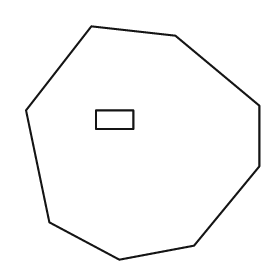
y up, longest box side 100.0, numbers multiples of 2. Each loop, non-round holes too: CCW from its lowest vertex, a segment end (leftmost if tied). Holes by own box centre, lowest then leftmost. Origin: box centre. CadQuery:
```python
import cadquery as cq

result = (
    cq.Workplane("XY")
    .moveTo(-10.0, -50.0)
    .lineTo(22.0, -44.0)
    .lineTo(50.0, -10.0)
    .lineTo(50.0, 16.0)
    .lineTo(14.0, 46.0)
    .lineTo(-22.0, 50.0)
    .lineTo(-50.0, 14.0)
    .lineTo(-40.0, -34.0)
    .close()
    .moveTo(-20.0, 6.0)
    .lineTo(-4.0, 6.0)
    .lineTo(-4.0, 14.0)
    .lineTo(-20.0, 14.0)
    .close()
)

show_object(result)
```